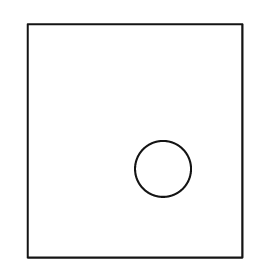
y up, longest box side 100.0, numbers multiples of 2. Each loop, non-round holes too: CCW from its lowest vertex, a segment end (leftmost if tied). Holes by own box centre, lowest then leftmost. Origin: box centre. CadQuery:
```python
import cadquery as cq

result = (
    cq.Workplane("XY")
    .moveTo(-46.0, -50.0)
    .lineTo(46.0, -50.0)
    .lineTo(46.0, 50.0)
    .lineTo(-46.0, 50.0)
    .close()
    .moveTo(12.0, -12.0)
    .circle(12.0)
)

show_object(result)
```